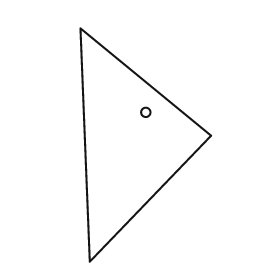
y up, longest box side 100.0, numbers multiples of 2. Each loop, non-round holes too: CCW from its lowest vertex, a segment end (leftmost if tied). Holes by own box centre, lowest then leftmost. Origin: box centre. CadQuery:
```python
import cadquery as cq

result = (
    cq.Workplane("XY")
    .moveTo(-24.0, -50.0)
    .lineTo(28.0, 4.0)
    .lineTo(-28.0, 50.0)
    .close()
    .moveTo(0.0, 14.0)
    .circle(2.0)
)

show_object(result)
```